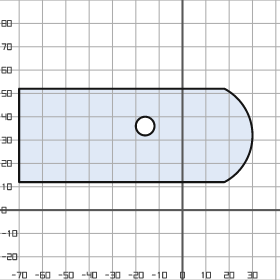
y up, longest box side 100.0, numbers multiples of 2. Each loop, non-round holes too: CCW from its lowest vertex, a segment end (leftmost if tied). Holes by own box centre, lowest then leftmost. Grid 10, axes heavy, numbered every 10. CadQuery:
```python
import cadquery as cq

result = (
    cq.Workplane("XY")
    .moveTo(-70.0, 12.0)
    .lineTo(18.0, 12.0)
    .threePointArc((30.0, 32.0), (18.0, 52.0))
    .lineTo(-70.0, 52.0)
    .close()
    .moveTo(-16.0, 36.0)
    .circle(4.0)
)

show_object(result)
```